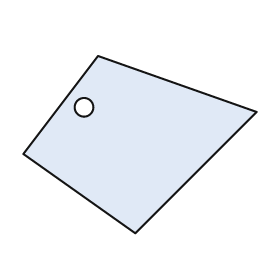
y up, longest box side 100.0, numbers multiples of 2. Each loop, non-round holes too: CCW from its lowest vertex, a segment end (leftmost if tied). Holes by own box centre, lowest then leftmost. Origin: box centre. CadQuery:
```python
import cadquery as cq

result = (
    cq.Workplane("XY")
    .moveTo(-2.0, -38.0)
    .lineTo(50.0, 14.0)
    .lineTo(-18.0, 38.0)
    .lineTo(-50.0, -4.0)
    .close()
    .moveTo(-24.0, 16.0)
    .circle(4.0)
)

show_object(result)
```